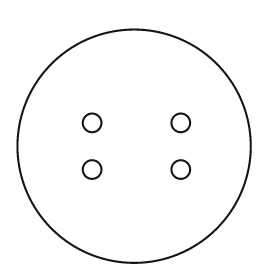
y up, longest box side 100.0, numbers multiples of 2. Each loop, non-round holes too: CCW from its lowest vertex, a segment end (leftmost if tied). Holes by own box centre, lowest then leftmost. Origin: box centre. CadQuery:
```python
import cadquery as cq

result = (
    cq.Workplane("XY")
    .moveTo(0.0, 0.0)
    .circle(50.0)
    .moveTo(-18.0, -10.0)
    .circle(4.0)
    .moveTo(20.0, -10.0)
    .circle(4.0)
    .moveTo(-18.0, 10.0)
    .circle(4.0)
    .moveTo(20.0, 10.0)
    .circle(4.0)
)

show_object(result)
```